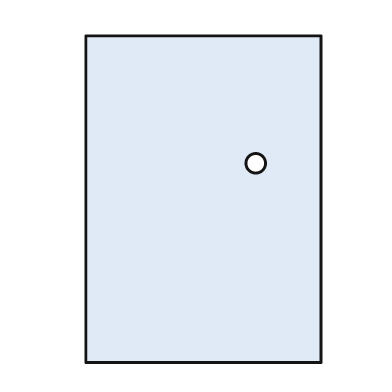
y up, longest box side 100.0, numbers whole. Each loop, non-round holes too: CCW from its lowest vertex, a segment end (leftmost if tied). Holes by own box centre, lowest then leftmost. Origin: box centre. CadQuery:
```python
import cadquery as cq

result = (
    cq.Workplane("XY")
    .moveTo(-36.0, -50.0)
    .lineTo(36.0, -50.0)
    .lineTo(36.0, 50.0)
    .lineTo(-36.0, 50.0)
    .close()
    .moveTo(16.0, 11.0)
    .circle(3.0)
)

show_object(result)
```